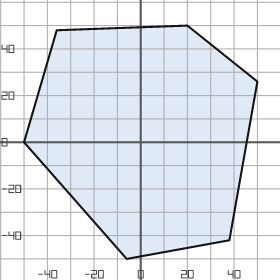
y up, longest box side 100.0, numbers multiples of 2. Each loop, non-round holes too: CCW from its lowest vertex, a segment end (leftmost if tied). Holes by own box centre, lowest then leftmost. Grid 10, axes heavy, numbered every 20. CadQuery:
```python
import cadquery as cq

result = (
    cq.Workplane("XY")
    .moveTo(-6.0, -50.0)
    .lineTo(38.0, -42.0)
    .lineTo(50.0, 26.0)
    .lineTo(20.0, 50.0)
    .lineTo(-36.0, 48.0)
    .lineTo(-50.0, 0.0)
    .close()
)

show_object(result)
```